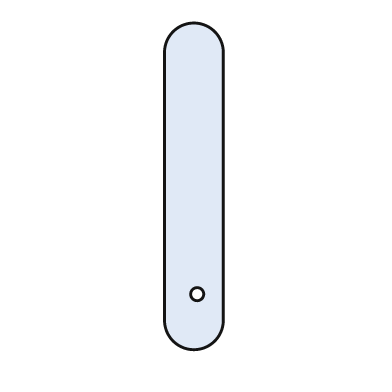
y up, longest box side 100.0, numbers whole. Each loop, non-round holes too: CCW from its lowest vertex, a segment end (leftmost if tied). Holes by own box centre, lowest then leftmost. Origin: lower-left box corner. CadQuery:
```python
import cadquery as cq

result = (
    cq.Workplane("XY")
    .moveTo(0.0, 9.0)
    .threePointArc((9.0, 0.0), (18.0, 9.0))
    .lineTo(18.0, 91.0)
    .threePointArc((9.0, 100.0), (0.0, 91.0))
    .close()
    .moveTo(10.0, 17.0)
    .circle(2.0)
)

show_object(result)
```